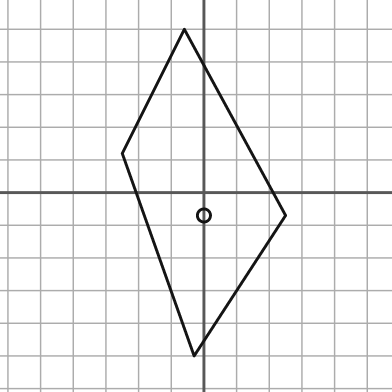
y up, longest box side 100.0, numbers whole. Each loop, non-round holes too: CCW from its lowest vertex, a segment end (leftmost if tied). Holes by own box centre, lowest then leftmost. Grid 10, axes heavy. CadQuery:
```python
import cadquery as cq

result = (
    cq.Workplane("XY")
    .moveTo(-3.0, -50.0)
    .lineTo(25.0, -7.0)
    .lineTo(-6.0, 50.0)
    .lineTo(-25.0, 12.0)
    .close()
    .moveTo(0.0, -7.0)
    .circle(2.0)
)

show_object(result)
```